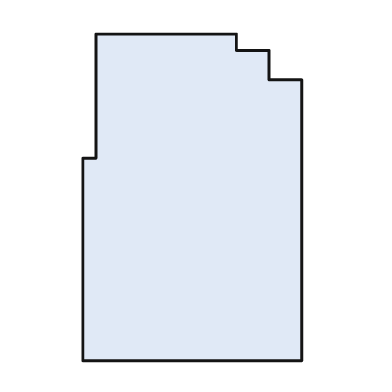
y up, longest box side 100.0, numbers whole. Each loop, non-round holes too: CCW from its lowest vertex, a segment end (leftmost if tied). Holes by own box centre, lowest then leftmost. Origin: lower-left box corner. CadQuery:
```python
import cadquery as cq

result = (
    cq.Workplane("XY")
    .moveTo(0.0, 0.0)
    .lineTo(67.0, 0.0)
    .lineTo(67.0, 86.0)
    .lineTo(57.0, 86.0)
    .lineTo(57.0, 95.0)
    .lineTo(47.0, 95.0)
    .lineTo(47.0, 100.0)
    .lineTo(4.0, 100.0)
    .lineTo(4.0, 62.0)
    .lineTo(0.0, 62.0)
    .close()
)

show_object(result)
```